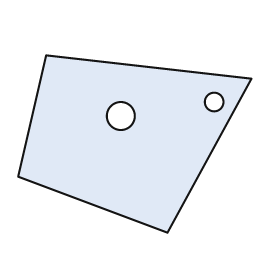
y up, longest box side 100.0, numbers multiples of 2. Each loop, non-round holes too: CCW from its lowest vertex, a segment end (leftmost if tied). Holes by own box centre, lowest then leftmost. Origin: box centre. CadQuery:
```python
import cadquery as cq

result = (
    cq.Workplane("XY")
    .moveTo(14.0, -38.0)
    .lineTo(50.0, 28.0)
    .lineTo(-38.0, 38.0)
    .lineTo(-50.0, -14.0)
    .close()
    .moveTo(-6.0, 12.0)
    .circle(6.0)
    .moveTo(34.0, 18.0)
    .circle(4.0)
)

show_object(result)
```